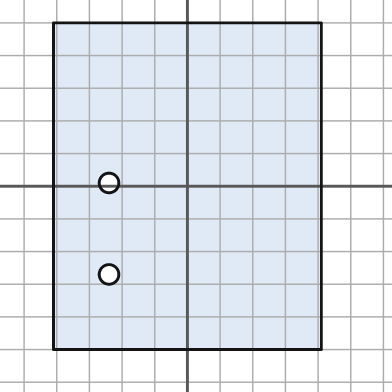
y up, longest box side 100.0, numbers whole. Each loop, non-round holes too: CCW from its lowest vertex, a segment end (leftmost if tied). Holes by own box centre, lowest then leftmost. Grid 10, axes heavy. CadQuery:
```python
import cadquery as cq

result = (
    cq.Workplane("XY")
    .moveTo(-41.0, -50.0)
    .lineTo(41.0, -50.0)
    .lineTo(41.0, 50.0)
    .lineTo(-41.0, 50.0)
    .close()
    .moveTo(-24.0, -27.0)
    .circle(3.0)
    .moveTo(-24.0, 1.0)
    .circle(3.0)
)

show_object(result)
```